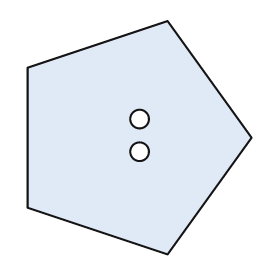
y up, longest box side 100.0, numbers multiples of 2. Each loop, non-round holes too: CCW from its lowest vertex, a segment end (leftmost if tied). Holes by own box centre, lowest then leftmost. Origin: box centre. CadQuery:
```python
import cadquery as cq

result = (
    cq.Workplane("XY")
    .moveTo(12.0, -50.0)
    .lineTo(48.0, 0.0)
    .lineTo(12.0, 50.0)
    .lineTo(-48.0, 30.0)
    .lineTo(-48.0, -30.0)
    .close()
    .moveTo(0.0, -6.0)
    .circle(4.0)
    .moveTo(0.0, 8.0)
    .circle(4.0)
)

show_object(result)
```